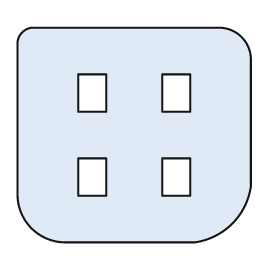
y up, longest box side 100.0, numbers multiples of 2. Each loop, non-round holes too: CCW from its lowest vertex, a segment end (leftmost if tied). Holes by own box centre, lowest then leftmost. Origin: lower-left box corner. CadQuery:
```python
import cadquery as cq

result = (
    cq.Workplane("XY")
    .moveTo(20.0, 0.0)
    .lineTo(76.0, 0.0)
    .threePointArc((92.0, 8.0), (100.0, 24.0))
    .lineTo(100.0, 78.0)
    .threePointArc((96.0, 88.0), (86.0, 92.0))
    .lineTo(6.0, 92.0)
    .threePointArc((2.0, 90.0), (0.0, 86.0))
    .lineTo(0.0, 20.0)
    .threePointArc((6.0, 6.0), (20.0, 0.0))
    .close()
    .moveTo(26.0, 20.0)
    .lineTo(38.0, 20.0)
    .lineTo(38.0, 36.0)
    .lineTo(26.0, 36.0)
    .close()
    .moveTo(62.0, 20.0)
    .lineTo(74.0, 20.0)
    .lineTo(74.0, 36.0)
    .lineTo(62.0, 36.0)
    .close()
    .moveTo(26.0, 56.0)
    .lineTo(38.0, 56.0)
    .lineTo(38.0, 72.0)
    .lineTo(26.0, 72.0)
    .close()
    .moveTo(62.0, 56.0)
    .lineTo(74.0, 56.0)
    .lineTo(74.0, 72.0)
    .lineTo(62.0, 72.0)
    .close()
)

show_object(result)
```